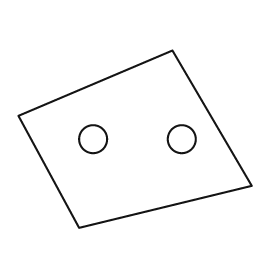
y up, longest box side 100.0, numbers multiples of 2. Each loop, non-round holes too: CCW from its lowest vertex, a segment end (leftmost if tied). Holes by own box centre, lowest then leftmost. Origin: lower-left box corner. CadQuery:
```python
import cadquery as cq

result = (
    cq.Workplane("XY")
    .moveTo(26.0, 0.0)
    .lineTo(100.0, 18.0)
    .lineTo(66.0, 76.0)
    .lineTo(0.0, 48.0)
    .close()
    .moveTo(32.0, 38.0)
    .circle(6.0)
    .moveTo(70.0, 38.0)
    .circle(6.0)
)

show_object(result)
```